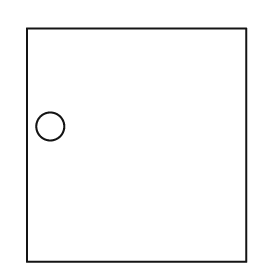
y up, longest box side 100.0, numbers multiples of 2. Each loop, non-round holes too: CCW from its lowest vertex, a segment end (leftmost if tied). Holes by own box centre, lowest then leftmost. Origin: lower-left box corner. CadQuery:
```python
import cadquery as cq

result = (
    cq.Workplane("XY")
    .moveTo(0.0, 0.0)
    .lineTo(94.0, 0.0)
    .lineTo(94.0, 100.0)
    .lineTo(0.0, 100.0)
    .close()
    .moveTo(10.0, 58.0)
    .circle(6.0)
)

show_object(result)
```